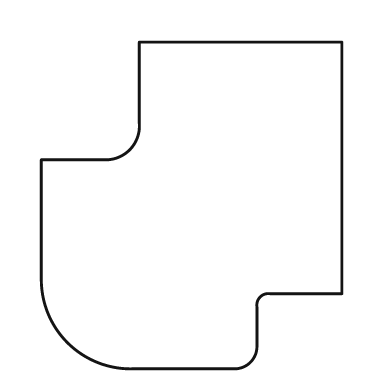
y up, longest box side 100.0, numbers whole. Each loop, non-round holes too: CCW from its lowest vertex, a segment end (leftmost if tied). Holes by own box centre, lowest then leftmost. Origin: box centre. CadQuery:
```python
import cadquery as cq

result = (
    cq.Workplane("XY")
    .moveTo(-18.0, -50.0)
    .lineTo(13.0, -50.0)
    .threePointArc((18.0, -48.0), (20.0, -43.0))
    .lineTo(20.0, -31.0)
    .threePointArc((21.0, -28.0), (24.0, -27.0))
    .lineTo(46.0, -27.0)
    .lineTo(46.0, 50.0)
    .lineTo(-16.0, 50.0)
    .lineTo(-16.0, 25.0)
    .threePointArc((-19.0, 17.0), (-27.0, 14.0))
    .lineTo(-46.0, 14.0)
    .lineTo(-46.0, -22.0)
    .threePointArc((-38.0, -42.0), (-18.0, -50.0))
    .close()
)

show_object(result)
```